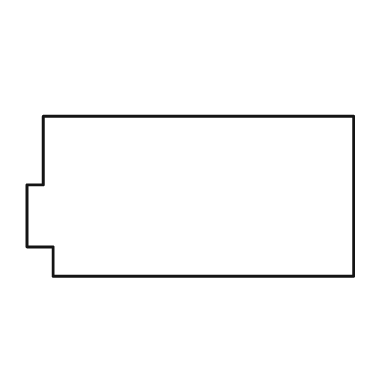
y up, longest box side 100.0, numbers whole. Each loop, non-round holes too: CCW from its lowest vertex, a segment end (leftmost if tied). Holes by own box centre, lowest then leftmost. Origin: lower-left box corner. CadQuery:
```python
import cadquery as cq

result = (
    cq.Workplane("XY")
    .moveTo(8.0, 0.0)
    .lineTo(100.0, 0.0)
    .lineTo(100.0, 49.0)
    .lineTo(5.0, 49.0)
    .lineTo(5.0, 28.0)
    .lineTo(0.0, 28.0)
    .lineTo(0.0, 9.0)
    .lineTo(8.0, 9.0)
    .close()
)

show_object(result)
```